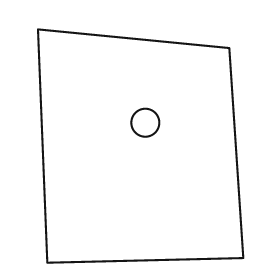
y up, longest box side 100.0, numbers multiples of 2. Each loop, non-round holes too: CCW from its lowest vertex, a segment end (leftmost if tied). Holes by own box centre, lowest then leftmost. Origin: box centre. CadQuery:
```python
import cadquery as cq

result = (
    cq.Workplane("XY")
    .moveTo(-40.0, -50.0)
    .lineTo(44.0, -48.0)
    .lineTo(38.0, 42.0)
    .lineTo(-44.0, 50.0)
    .close()
    .moveTo(2.0, 10.0)
    .circle(6.0)
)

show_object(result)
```